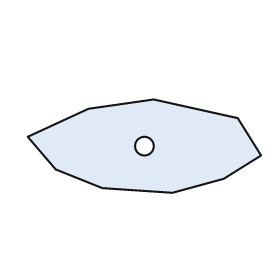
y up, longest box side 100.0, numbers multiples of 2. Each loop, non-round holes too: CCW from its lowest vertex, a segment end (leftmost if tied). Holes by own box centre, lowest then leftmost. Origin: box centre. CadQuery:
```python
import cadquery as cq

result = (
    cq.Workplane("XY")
    .moveTo(12.0, -20.0)
    .lineTo(34.0, -14.0)
    .lineTo(50.0, -4.0)
    .lineTo(40.0, 12.0)
    .lineTo(4.0, 20.0)
    .lineTo(-24.0, 16.0)
    .lineTo(-50.0, 4.0)
    .lineTo(-38.0, -10.0)
    .lineTo(-18.0, -18.0)
    .close()
    .moveTo(0.0, 0.0)
    .circle(4.0)
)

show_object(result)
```